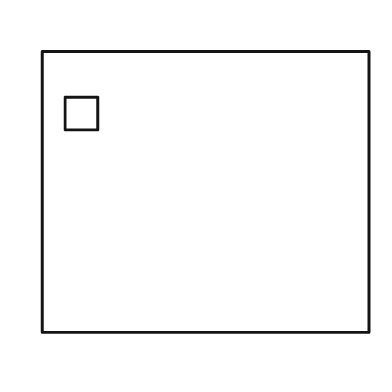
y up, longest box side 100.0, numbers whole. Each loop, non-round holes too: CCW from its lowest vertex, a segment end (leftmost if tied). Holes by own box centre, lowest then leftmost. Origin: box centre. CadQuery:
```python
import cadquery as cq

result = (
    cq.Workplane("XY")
    .moveTo(-50.0, -43.0)
    .lineTo(50.0, -43.0)
    .lineTo(50.0, 43.0)
    .lineTo(-50.0, 43.0)
    .close()
    .moveTo(-43.0, 19.0)
    .lineTo(-33.0, 19.0)
    .lineTo(-33.0, 29.0)
    .lineTo(-43.0, 29.0)
    .close()
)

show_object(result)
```